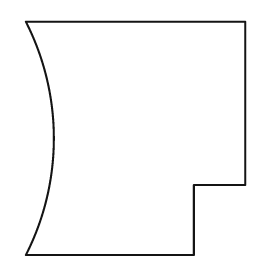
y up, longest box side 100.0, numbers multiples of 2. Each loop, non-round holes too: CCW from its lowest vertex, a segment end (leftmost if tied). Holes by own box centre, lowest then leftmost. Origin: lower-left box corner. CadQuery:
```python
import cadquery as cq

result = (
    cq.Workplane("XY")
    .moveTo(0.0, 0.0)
    .lineTo(72.0, 0.0)
    .lineTo(72.0, 30.0)
    .lineTo(94.0, 30.0)
    .lineTo(94.0, 100.0)
    .lineTo(0.0, 100.0)
    .threePointArc((12.0, 50.0), (0.0, 0.0))
    .close()
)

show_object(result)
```